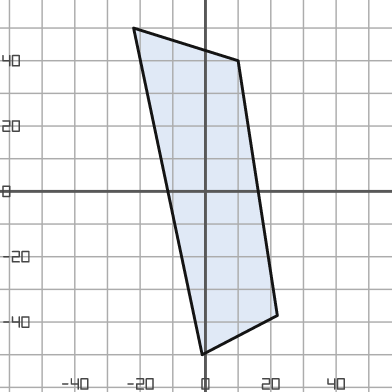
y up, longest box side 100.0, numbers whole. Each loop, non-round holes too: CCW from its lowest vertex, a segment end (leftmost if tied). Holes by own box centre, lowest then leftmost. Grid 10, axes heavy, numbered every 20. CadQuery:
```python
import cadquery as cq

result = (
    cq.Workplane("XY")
    .moveTo(-1.0, -50.0)
    .lineTo(22.0, -38.0)
    .lineTo(10.0, 40.0)
    .lineTo(-22.0, 50.0)
    .close()
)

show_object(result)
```